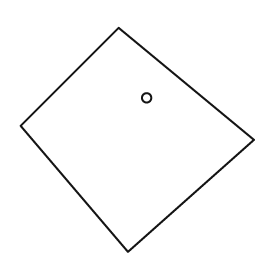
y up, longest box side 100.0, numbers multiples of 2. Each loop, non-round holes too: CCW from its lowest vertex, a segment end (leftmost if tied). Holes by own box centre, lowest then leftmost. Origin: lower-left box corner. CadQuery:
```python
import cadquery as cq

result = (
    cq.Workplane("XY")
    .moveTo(46.0, 0.0)
    .lineTo(100.0, 48.0)
    .lineTo(42.0, 96.0)
    .lineTo(0.0, 54.0)
    .close()
    .moveTo(54.0, 66.0)
    .circle(2.0)
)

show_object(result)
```